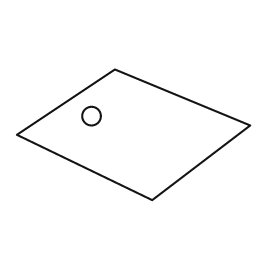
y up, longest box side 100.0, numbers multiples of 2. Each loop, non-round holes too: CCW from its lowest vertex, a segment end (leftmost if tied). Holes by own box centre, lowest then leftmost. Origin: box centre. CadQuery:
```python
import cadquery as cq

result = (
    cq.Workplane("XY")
    .moveTo(8.0, -28.0)
    .lineTo(50.0, 4.0)
    .lineTo(-8.0, 28.0)
    .lineTo(-50.0, 0.0)
    .close()
    .moveTo(-18.0, 8.0)
    .circle(4.0)
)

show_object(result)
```